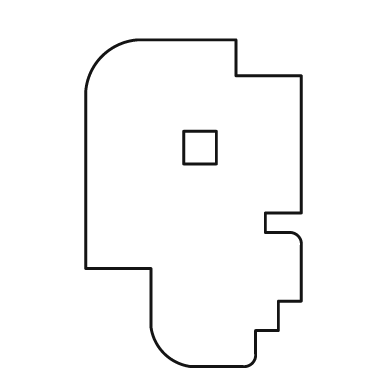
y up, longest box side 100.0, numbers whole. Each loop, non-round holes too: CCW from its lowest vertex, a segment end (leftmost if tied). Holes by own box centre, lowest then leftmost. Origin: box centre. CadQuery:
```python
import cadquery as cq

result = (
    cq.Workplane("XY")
    .moveTo(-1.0, -50.0)
    .lineTo(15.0, -50.0)
    .threePointArc((18.0, -49.0), (19.0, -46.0))
    .lineTo(19.0, -39.0)
    .lineTo(26.0, -39.0)
    .lineTo(26.0, -30.0)
    .lineTo(33.0, -30.0)
    .lineTo(33.0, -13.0)
    .threePointArc((32.0, -10.0), (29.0, -9.0))
    .lineTo(22.0, -9.0)
    .lineTo(22.0, -3.0)
    .lineTo(33.0, -3.0)
    .lineTo(33.0, 39.0)
    .lineTo(13.0, 39.0)
    .lineTo(13.0, 50.0)
    .lineTo(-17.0, 50.0)
    .threePointArc((-28.0, 45.0), (-33.0, 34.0))
    .lineTo(-33.0, -20.0)
    .lineTo(-13.0, -20.0)
    .lineTo(-13.0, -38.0)
    .threePointArc((-9.0, -46.0), (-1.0, -50.0))
    .close()
    .moveTo(-3.0, 12.0)
    .lineTo(7.0, 12.0)
    .lineTo(7.0, 22.0)
    .lineTo(-3.0, 22.0)
    .close()
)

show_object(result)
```